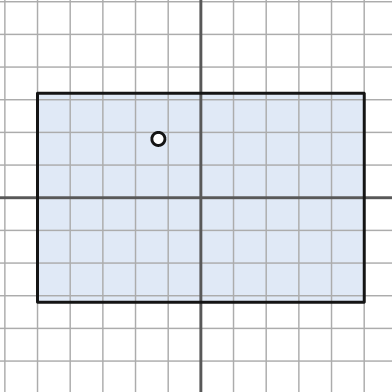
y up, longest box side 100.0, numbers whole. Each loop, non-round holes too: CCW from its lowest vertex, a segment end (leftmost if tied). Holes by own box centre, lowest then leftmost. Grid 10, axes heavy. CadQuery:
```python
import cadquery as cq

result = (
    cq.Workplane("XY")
    .moveTo(-50.0, -32.0)
    .lineTo(50.0, -32.0)
    .lineTo(50.0, 32.0)
    .lineTo(-50.0, 32.0)
    .close()
    .moveTo(-13.0, 18.0)
    .circle(2.0)
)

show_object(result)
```